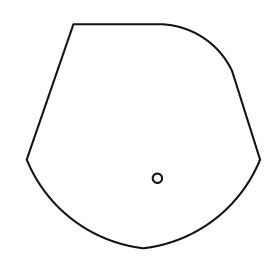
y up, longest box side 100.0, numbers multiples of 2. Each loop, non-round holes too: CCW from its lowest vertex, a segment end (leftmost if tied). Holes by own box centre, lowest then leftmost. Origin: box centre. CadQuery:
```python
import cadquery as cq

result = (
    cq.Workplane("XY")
    .moveTo(0.0, -48.0)
    .threePointArc((30.0, -36.0), (50.0, -10.0))
    .lineTo(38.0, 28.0)
    .threePointArc((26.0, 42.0), (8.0, 48.0))
    .lineTo(-30.0, 48.0)
    .lineTo(-50.0, -10.0)
    .threePointArc((-30.0, -36.0), (0.0, -48.0))
    .close()
    .moveTo(6.0, -18.0)
    .circle(2.0)
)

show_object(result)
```